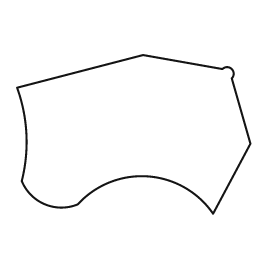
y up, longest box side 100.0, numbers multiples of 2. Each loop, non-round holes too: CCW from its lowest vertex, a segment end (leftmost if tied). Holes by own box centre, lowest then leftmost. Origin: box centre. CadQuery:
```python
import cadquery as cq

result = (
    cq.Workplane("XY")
    .moveTo(34.0, -34.0)
    .lineTo(50.0, -4.0)
    .lineTo(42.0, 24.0)
    .threePointArc((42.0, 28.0), (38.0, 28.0))
    .lineTo(4.0, 34.0)
    .lineTo(-50.0, 20.0)
    .threePointArc((-46.0, 0.0), (-48.0, -20.0))
    .threePointArc((-38.0, -30.0), (-24.0, -30.0))
    .threePointArc((6.0, -18.0), (34.0, -34.0))
    .close()
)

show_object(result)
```